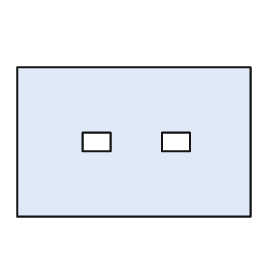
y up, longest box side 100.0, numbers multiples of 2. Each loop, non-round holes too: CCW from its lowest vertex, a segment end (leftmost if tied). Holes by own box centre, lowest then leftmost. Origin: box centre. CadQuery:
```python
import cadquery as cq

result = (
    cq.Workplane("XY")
    .moveTo(-50.0, -32.0)
    .lineTo(50.0, -32.0)
    .lineTo(50.0, 32.0)
    .lineTo(-50.0, 32.0)
    .close()
    .moveTo(-22.0, -4.0)
    .lineTo(-10.0, -4.0)
    .lineTo(-10.0, 4.0)
    .lineTo(-22.0, 4.0)
    .close()
    .moveTo(12.0, -4.0)
    .lineTo(24.0, -4.0)
    .lineTo(24.0, 4.0)
    .lineTo(12.0, 4.0)
    .close()
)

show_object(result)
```